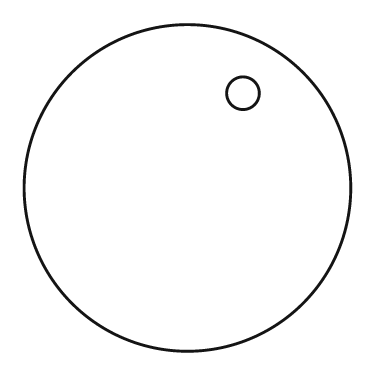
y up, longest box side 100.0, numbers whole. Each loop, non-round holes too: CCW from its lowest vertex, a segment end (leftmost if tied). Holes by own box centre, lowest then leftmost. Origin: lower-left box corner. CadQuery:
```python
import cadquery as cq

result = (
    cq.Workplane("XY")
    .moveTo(50.0, 50.0)
    .circle(50.0)
    .moveTo(67.0, 79.0)
    .circle(5.0)
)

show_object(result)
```